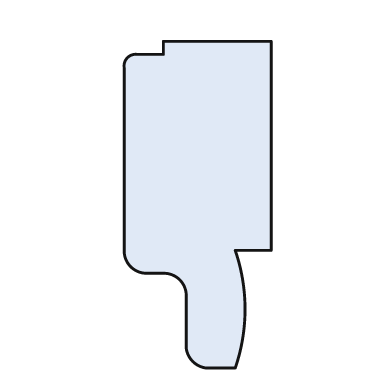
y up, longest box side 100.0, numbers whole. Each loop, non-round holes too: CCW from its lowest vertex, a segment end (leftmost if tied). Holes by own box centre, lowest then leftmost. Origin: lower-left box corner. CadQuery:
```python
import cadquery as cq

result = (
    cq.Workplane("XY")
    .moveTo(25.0, 0.0)
    .lineTo(34.0, 0.0)
    .threePointArc((37.0, 18.0), (34.0, 36.0))
    .lineTo(45.0, 36.0)
    .lineTo(45.0, 100.0)
    .lineTo(12.0, 100.0)
    .lineTo(12.0, 96.0)
    .lineTo(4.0, 96.0)
    .threePointArc((1.0, 95.0), (0.0, 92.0))
    .lineTo(0.0, 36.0)
    .threePointArc((2.0, 31.0), (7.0, 29.0))
    .lineTo(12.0, 29.0)
    .threePointArc((17.0, 27.0), (19.0, 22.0))
    .lineTo(19.0, 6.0)
    .threePointArc((21.0, 2.0), (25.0, 0.0))
    .close()
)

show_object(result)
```